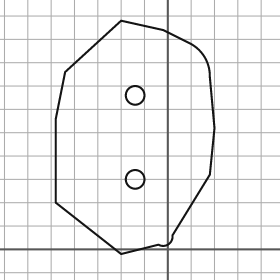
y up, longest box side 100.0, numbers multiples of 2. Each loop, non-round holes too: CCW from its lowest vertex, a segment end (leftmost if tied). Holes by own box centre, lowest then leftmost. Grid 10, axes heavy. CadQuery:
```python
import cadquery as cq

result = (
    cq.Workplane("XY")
    .moveTo(-20.0, -2.0)
    .lineTo(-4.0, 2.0)
    .threePointArc((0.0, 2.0), (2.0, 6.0))
    .lineTo(18.0, 32.0)
    .lineTo(20.0, 52.0)
    .lineTo(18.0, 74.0)
    .threePointArc((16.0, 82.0), (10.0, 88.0))
    .lineTo(-2.0, 94.0)
    .lineTo(-20.0, 98.0)
    .lineTo(-44.0, 76.0)
    .lineTo(-48.0, 56.0)
    .lineTo(-48.0, 20.0)
    .close()
    .moveTo(-14.0, 30.0)
    .circle(4.0)
    .moveTo(-14.0, 66.0)
    .circle(4.0)
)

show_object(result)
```